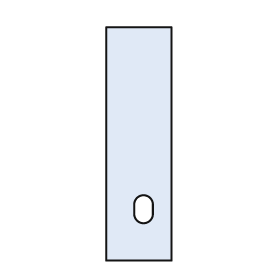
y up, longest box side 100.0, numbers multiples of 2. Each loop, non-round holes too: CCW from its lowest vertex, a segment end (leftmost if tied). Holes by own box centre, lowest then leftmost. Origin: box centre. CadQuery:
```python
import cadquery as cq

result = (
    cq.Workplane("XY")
    .moveTo(-14.0, -50.0)
    .lineTo(14.0, -50.0)
    .lineTo(14.0, 50.0)
    .lineTo(-14.0, 50.0)
    .close()
    .moveTo(-2.0, -30.0)
    .threePointArc((2.0, -34.0), (6.0, -30.0))
    .lineTo(6.0, -26.0)
    .threePointArc((2.0, -22.0), (-2.0, -26.0))
    .close()
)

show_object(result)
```